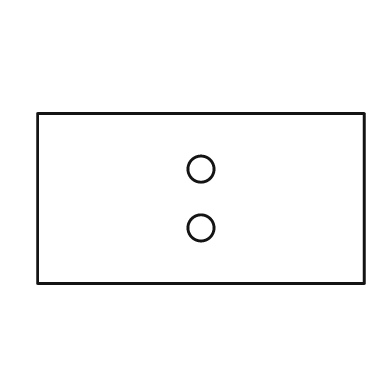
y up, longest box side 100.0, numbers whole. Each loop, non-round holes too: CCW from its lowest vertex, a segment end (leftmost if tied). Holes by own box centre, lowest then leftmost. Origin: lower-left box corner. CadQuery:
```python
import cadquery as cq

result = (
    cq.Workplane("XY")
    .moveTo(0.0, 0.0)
    .lineTo(100.0, 0.0)
    .lineTo(100.0, 52.0)
    .lineTo(0.0, 52.0)
    .close()
    .moveTo(50.0, 17.0)
    .circle(4.0)
    .moveTo(50.0, 35.0)
    .circle(4.0)
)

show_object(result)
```